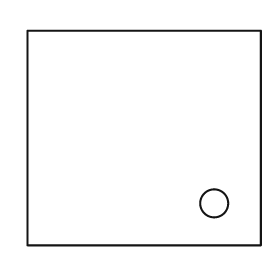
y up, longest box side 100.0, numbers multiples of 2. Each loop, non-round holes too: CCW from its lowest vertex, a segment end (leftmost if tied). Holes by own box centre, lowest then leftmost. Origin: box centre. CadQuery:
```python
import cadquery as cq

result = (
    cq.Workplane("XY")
    .moveTo(-50.0, -46.0)
    .lineTo(50.0, -46.0)
    .lineTo(50.0, 46.0)
    .lineTo(-50.0, 46.0)
    .close()
    .moveTo(30.0, -28.0)
    .circle(6.0)
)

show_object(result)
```